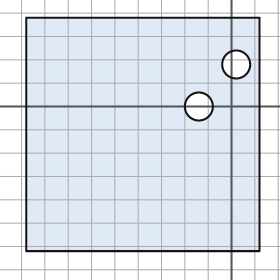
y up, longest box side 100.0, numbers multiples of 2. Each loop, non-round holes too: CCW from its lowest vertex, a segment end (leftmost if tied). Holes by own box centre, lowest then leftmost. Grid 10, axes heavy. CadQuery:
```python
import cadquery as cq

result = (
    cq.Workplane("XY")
    .moveTo(-88.0, -62.0)
    .lineTo(12.0, -62.0)
    .lineTo(12.0, 38.0)
    .lineTo(-88.0, 38.0)
    .close()
    .moveTo(-14.0, 0.0)
    .circle(6.0)
    .moveTo(2.0, 18.0)
    .circle(6.0)
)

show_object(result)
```